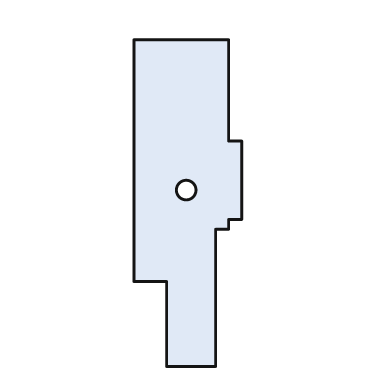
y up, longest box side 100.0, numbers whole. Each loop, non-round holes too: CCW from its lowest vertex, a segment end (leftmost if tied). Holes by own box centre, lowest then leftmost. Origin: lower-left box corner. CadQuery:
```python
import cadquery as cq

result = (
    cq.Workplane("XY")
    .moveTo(10.0, 0.0)
    .lineTo(25.0, 0.0)
    .lineTo(25.0, 42.0)
    .lineTo(29.0, 42.0)
    .lineTo(29.0, 45.0)
    .lineTo(33.0, 45.0)
    .lineTo(33.0, 69.0)
    .lineTo(29.0, 69.0)
    .lineTo(29.0, 100.0)
    .lineTo(0.0, 100.0)
    .lineTo(0.0, 26.0)
    .lineTo(10.0, 26.0)
    .close()
    .moveTo(16.0, 54.0)
    .circle(3.0)
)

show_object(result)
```